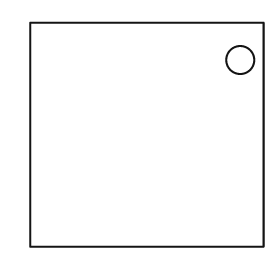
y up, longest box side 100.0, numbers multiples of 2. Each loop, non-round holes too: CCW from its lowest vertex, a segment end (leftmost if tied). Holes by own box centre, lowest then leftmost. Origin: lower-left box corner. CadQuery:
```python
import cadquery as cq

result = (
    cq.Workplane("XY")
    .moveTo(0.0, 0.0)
    .lineTo(100.0, 0.0)
    .lineTo(100.0, 96.0)
    .lineTo(0.0, 96.0)
    .close()
    .moveTo(90.0, 80.0)
    .circle(6.0)
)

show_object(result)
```